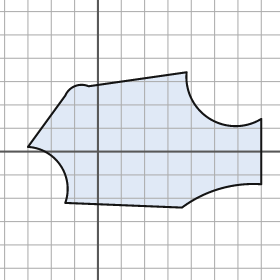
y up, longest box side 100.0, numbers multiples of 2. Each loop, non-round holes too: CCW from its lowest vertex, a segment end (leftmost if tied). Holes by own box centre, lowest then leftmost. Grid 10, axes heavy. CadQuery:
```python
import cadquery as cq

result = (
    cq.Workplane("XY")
    .moveTo(36.0, -24.0)
    .threePointArc((52.0, -16.0), (70.0, -14.0))
    .lineTo(70.0, 14.0)
    .threePointArc((48.0, 14.0), (38.0, 34.0))
    .lineTo(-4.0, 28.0)
    .threePointArc((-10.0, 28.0), (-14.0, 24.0))
    .lineTo(-30.0, 2.0)
    .threePointArc((-16.0, -6.0), (-14.0, -22.0))
    .close()
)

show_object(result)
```